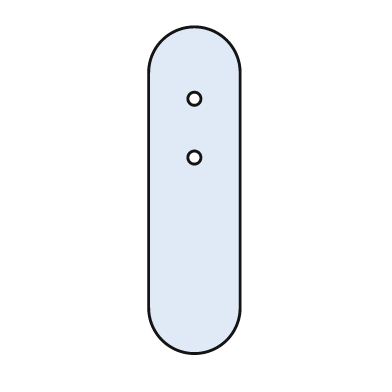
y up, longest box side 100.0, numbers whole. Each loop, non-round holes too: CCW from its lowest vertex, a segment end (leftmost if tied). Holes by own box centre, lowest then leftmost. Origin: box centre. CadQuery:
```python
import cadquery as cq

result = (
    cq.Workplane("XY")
    .moveTo(-14.0, -36.0)
    .threePointArc((0.0, -50.0), (14.0, -36.0))
    .lineTo(14.0, 36.0)
    .threePointArc((0.0, 50.0), (-14.0, 36.0))
    .close()
    .moveTo(0.0, 10.0)
    .circle(2.0)
    .moveTo(0.0, 28.0)
    .circle(2.0)
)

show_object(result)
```